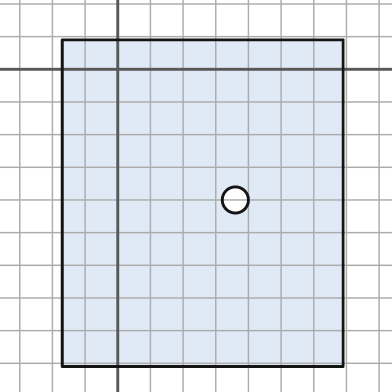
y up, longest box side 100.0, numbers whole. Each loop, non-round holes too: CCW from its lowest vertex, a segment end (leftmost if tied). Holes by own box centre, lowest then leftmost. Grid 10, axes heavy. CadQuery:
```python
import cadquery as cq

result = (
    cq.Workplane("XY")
    .moveTo(-17.0, -91.0)
    .lineTo(69.0, -91.0)
    .lineTo(69.0, 9.0)
    .lineTo(-17.0, 9.0)
    .close()
    .moveTo(36.0, -40.0)
    .circle(4.0)
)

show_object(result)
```